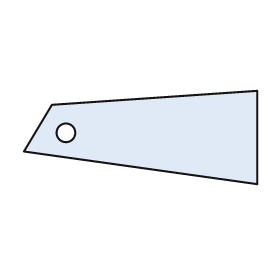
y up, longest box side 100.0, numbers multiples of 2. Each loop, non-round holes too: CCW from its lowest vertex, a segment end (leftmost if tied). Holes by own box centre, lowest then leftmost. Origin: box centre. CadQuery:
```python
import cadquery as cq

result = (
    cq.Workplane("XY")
    .moveTo(50.0, -20.0)
    .lineTo(50.0, 20.0)
    .lineTo(-38.0, 14.0)
    .lineTo(-50.0, -6.0)
    .close()
    .moveTo(-32.0, 2.0)
    .circle(4.0)
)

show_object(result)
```